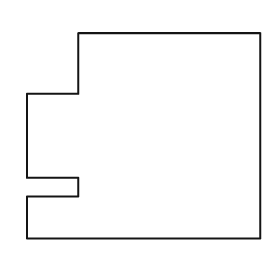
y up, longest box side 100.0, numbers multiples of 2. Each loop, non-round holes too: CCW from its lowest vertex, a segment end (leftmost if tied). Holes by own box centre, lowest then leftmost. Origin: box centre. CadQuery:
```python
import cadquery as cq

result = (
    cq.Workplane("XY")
    .moveTo(-50.0, -44.0)
    .lineTo(50.0, -44.0)
    .lineTo(50.0, 44.0)
    .lineTo(-28.0, 44.0)
    .lineTo(-28.0, 18.0)
    .lineTo(-50.0, 18.0)
    .lineTo(-50.0, -18.0)
    .lineTo(-28.0, -18.0)
    .lineTo(-28.0, -26.0)
    .lineTo(-50.0, -26.0)
    .close()
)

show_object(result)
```